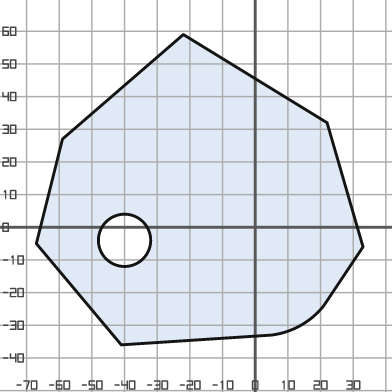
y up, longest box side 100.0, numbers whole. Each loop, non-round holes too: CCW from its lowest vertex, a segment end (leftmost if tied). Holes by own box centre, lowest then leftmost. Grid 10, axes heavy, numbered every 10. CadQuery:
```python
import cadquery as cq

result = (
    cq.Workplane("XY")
    .moveTo(-41.0, -36.0)
    .lineTo(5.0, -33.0)
    .threePointArc((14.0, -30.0), (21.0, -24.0))
    .lineTo(33.0, -6.0)
    .lineTo(22.0, 32.0)
    .lineTo(-22.0, 59.0)
    .lineTo(-59.0, 27.0)
    .lineTo(-67.0, -5.0)
    .close()
    .moveTo(-40.0, -4.0)
    .circle(8.0)
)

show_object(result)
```